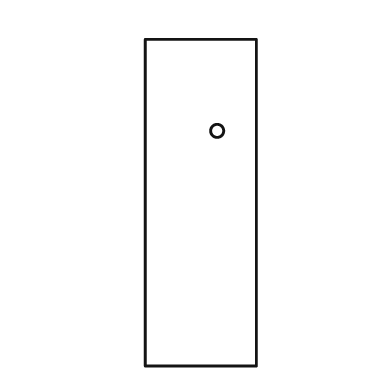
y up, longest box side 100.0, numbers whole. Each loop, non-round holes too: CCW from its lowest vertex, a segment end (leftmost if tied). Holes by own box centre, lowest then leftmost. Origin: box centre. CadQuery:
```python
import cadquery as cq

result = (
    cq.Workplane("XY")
    .moveTo(-17.0, -50.0)
    .lineTo(17.0, -50.0)
    .lineTo(17.0, 50.0)
    .lineTo(-17.0, 50.0)
    .close()
    .moveTo(5.0, 22.0)
    .circle(2.0)
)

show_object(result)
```